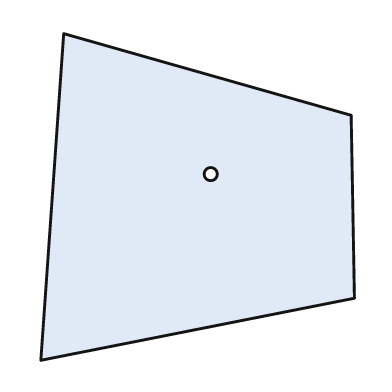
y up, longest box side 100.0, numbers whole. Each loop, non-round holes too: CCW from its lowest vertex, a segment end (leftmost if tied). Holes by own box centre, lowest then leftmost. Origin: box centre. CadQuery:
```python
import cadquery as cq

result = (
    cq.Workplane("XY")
    .moveTo(-48.0, -50.0)
    .lineTo(48.0, -31.0)
    .lineTo(47.0, 25.0)
    .lineTo(-41.0, 50.0)
    .close()
    .moveTo(4.0, 7.0)
    .circle(2.0)
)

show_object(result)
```